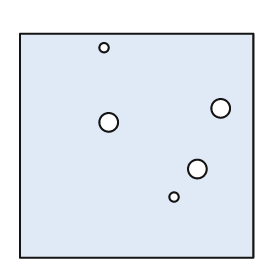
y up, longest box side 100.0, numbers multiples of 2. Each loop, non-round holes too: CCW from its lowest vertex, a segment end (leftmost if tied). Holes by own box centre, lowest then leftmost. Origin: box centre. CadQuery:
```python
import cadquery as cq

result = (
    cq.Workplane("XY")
    .moveTo(-50.0, -48.0)
    .lineTo(50.0, -48.0)
    .lineTo(50.0, 48.0)
    .lineTo(-50.0, 48.0)
    .close()
    .moveTo(16.0, -22.0)
    .circle(2.0)
    .moveTo(26.0, -10.0)
    .circle(4.0)
    .moveTo(-12.0, 10.0)
    .circle(4.0)
    .moveTo(36.0, 16.0)
    .circle(4.0)
    .moveTo(-14.0, 42.0)
    .circle(2.0)
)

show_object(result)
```